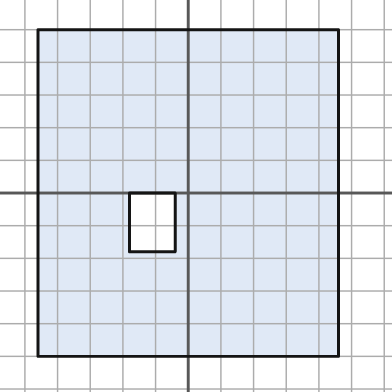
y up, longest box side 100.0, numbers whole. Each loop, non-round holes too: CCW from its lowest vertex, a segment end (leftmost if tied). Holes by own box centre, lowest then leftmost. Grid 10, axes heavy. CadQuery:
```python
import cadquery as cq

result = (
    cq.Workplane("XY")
    .moveTo(-46.0, -50.0)
    .lineTo(46.0, -50.0)
    .lineTo(46.0, 50.0)
    .lineTo(-46.0, 50.0)
    .close()
    .moveTo(-18.0, -18.0)
    .lineTo(-4.0, -18.0)
    .lineTo(-4.0, 0.0)
    .lineTo(-18.0, 0.0)
    .close()
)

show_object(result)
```